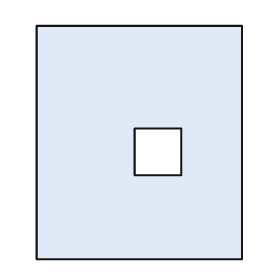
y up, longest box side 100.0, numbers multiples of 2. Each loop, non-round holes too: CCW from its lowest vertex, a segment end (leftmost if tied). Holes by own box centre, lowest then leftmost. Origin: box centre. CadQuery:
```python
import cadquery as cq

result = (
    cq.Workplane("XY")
    .moveTo(-44.0, -50.0)
    .lineTo(44.0, -50.0)
    .lineTo(44.0, 50.0)
    .lineTo(-44.0, 50.0)
    .close()
    .moveTo(-2.0, -14.0)
    .lineTo(18.0, -14.0)
    .lineTo(18.0, 6.0)
    .lineTo(-2.0, 6.0)
    .close()
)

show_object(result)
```